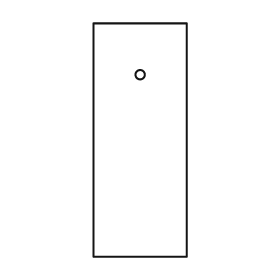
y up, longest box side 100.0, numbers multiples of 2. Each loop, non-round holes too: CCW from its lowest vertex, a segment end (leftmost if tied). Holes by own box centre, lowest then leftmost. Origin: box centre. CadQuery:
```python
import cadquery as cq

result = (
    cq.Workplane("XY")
    .moveTo(-20.0, -50.0)
    .lineTo(20.0, -50.0)
    .lineTo(20.0, 50.0)
    .lineTo(-20.0, 50.0)
    .close()
    .moveTo(0.0, 28.0)
    .circle(2.0)
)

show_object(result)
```